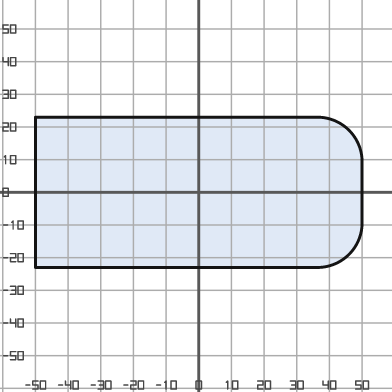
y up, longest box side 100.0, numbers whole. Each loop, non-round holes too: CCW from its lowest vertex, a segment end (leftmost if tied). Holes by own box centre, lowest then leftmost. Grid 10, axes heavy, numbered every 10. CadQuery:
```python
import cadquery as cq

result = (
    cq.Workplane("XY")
    .moveTo(-50.0, -23.0)
    .lineTo(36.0, -23.0)
    .threePointArc((46.0, -19.0), (50.0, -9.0))
    .lineTo(50.0, 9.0)
    .threePointArc((46.0, 19.0), (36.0, 23.0))
    .lineTo(-50.0, 23.0)
    .close()
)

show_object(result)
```